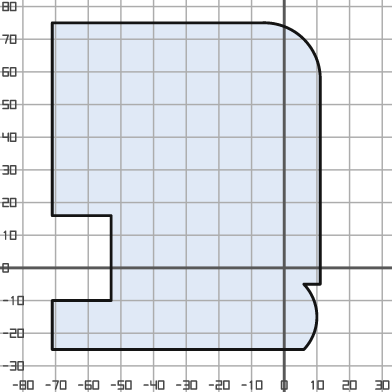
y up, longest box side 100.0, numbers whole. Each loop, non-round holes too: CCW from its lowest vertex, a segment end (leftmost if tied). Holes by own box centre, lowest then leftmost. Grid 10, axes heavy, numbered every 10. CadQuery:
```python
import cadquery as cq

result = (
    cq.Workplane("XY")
    .moveTo(-71.0, -25.0)
    .lineTo(6.0, -25.0)
    .threePointArc((10.0, -15.0), (6.0, -5.0))
    .lineTo(11.0, -5.0)
    .lineTo(11.0, 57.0)
    .threePointArc((6.0, 70.0), (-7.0, 75.0))
    .lineTo(-71.0, 75.0)
    .lineTo(-71.0, 16.0)
    .lineTo(-53.0, 16.0)
    .lineTo(-53.0, -10.0)
    .lineTo(-71.0, -10.0)
    .close()
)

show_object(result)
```